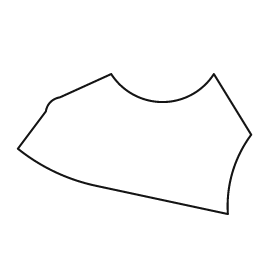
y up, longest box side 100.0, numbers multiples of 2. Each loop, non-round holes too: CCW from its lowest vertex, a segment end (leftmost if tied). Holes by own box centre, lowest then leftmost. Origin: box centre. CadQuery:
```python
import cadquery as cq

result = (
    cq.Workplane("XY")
    .moveTo(40.0, -30.0)
    .threePointArc((42.0, -12.0), (50.0, 4.0))
    .lineTo(34.0, 30.0)
    .threePointArc((12.0, 18.0), (-10.0, 30.0))
    .lineTo(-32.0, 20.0)
    .threePointArc((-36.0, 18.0), (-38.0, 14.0))
    .lineTo(-50.0, -2.0)
    .threePointArc((-34.0, -12.0), (-16.0, -18.0))
    .close()
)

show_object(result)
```